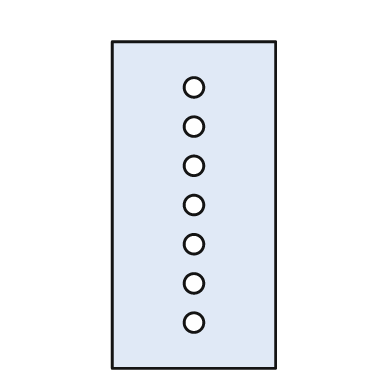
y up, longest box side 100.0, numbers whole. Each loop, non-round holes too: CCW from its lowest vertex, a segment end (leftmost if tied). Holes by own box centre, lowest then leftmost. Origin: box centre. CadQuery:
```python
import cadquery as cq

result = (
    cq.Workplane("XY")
    .moveTo(-25.0, -50.0)
    .lineTo(25.0, -50.0)
    .lineTo(25.0, 50.0)
    .lineTo(-25.0, 50.0)
    .close()
    .moveTo(0.0, -36.0)
    .circle(3.0)
    .moveTo(0.0, -24.0)
    .circle(3.0)
    .moveTo(0.0, -12.0)
    .circle(3.0)
    .moveTo(0.0, 0.0)
    .circle(3.0)
    .moveTo(0.0, 12.0)
    .circle(3.0)
    .moveTo(0.0, 24.0)
    .circle(3.0)
    .moveTo(0.0, 36.0)
    .circle(3.0)
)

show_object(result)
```